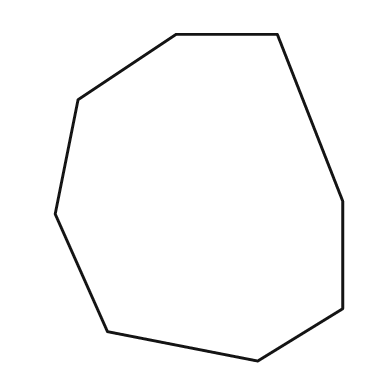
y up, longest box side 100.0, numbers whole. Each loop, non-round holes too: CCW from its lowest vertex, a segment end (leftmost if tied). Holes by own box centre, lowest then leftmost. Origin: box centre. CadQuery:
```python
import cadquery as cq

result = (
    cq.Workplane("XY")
    .moveTo(18.0, -50.0)
    .lineTo(44.0, -34.0)
    .lineTo(44.0, -1.0)
    .lineTo(24.0, 50.0)
    .lineTo(-7.0, 50.0)
    .lineTo(-37.0, 30.0)
    .lineTo(-44.0, -5.0)
    .lineTo(-28.0, -41.0)
    .close()
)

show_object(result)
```